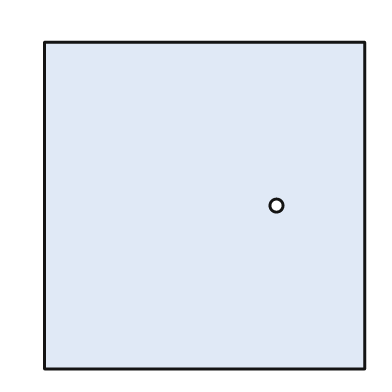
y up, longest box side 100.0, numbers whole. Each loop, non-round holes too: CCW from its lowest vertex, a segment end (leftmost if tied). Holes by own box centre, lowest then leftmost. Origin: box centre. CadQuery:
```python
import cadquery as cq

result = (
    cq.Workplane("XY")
    .moveTo(-49.0, -50.0)
    .lineTo(49.0, -50.0)
    .lineTo(49.0, 50.0)
    .lineTo(-49.0, 50.0)
    .close()
    .moveTo(22.0, 0.0)
    .circle(2.0)
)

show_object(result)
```